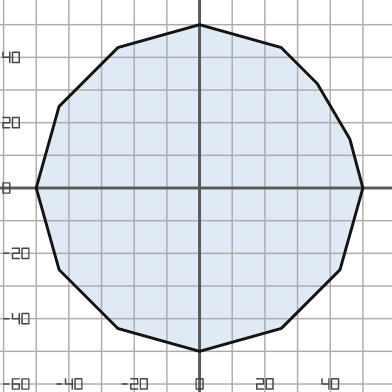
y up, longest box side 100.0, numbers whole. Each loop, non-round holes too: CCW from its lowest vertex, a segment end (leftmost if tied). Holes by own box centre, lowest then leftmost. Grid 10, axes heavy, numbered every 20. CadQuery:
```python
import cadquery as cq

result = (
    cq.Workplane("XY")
    .moveTo(0.0, -50.0)
    .lineTo(25.0, -43.0)
    .lineTo(43.0, -25.0)
    .lineTo(50.0, 0.0)
    .lineTo(46.0, 15.0)
    .lineTo(36.0, 32.0)
    .lineTo(25.0, 43.0)
    .lineTo(0.0, 50.0)
    .lineTo(-25.0, 43.0)
    .lineTo(-43.0, 25.0)
    .lineTo(-50.0, 0.0)
    .lineTo(-43.0, -25.0)
    .lineTo(-25.0, -43.0)
    .close()
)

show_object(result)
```